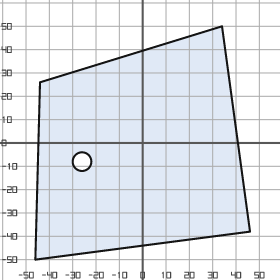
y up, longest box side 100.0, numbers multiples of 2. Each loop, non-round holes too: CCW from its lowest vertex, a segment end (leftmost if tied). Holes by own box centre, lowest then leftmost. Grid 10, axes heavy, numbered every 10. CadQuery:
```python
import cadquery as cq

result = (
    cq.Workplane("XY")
    .moveTo(-46.0, -50.0)
    .lineTo(46.0, -38.0)
    .lineTo(34.0, 50.0)
    .lineTo(-44.0, 26.0)
    .close()
    .moveTo(-26.0, -8.0)
    .circle(4.0)
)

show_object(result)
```